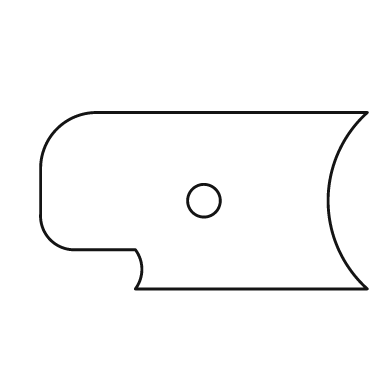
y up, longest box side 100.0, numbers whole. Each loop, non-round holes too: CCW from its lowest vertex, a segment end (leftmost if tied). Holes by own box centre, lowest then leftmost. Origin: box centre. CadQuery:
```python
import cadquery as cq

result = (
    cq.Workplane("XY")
    .moveTo(-21.0, -27.0)
    .lineTo(50.0, -27.0)
    .threePointArc((38.0, 0.0), (50.0, 27.0))
    .lineTo(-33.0, 27.0)
    .threePointArc((-45.0, 22.0), (-50.0, 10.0))
    .lineTo(-50.0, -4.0)
    .threePointArc((-47.0, -12.0), (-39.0, -15.0))
    .lineTo(-21.0, -15.0)
    .threePointArc((-19.0, -21.0), (-21.0, -27.0))
    .close()
    .moveTo(0.0, 0.0)
    .circle(5.0)
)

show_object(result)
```